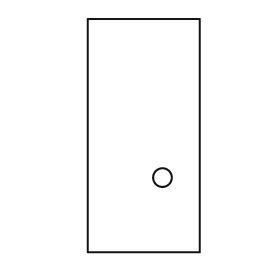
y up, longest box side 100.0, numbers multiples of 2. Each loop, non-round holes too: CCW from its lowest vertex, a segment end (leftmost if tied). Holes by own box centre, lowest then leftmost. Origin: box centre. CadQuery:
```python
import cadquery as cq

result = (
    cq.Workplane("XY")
    .moveTo(-24.0, -50.0)
    .lineTo(24.0, -50.0)
    .lineTo(24.0, 50.0)
    .lineTo(-24.0, 50.0)
    .close()
    .moveTo(8.0, -18.0)
    .circle(4.0)
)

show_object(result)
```